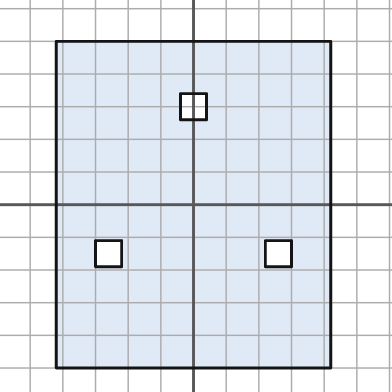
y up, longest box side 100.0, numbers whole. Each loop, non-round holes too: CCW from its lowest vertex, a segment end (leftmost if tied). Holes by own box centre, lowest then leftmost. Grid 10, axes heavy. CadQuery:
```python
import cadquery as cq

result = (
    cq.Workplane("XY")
    .moveTo(-42.0, -50.0)
    .lineTo(42.0, -50.0)
    .lineTo(42.0, 50.0)
    .lineTo(-42.0, 50.0)
    .close()
    .moveTo(-30.0, -19.0)
    .lineTo(-22.0, -19.0)
    .lineTo(-22.0, -11.0)
    .lineTo(-30.0, -11.0)
    .close()
    .moveTo(22.0, -19.0)
    .lineTo(30.0, -19.0)
    .lineTo(30.0, -11.0)
    .lineTo(22.0, -11.0)
    .close()
    .moveTo(-4.0, 26.0)
    .lineTo(4.0, 26.0)
    .lineTo(4.0, 34.0)
    .lineTo(-4.0, 34.0)
    .close()
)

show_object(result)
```